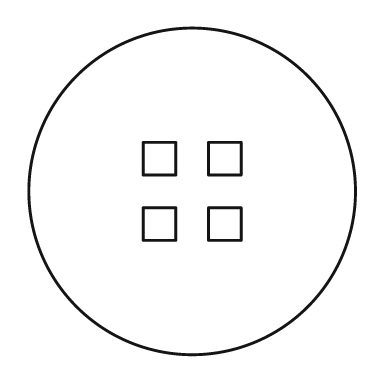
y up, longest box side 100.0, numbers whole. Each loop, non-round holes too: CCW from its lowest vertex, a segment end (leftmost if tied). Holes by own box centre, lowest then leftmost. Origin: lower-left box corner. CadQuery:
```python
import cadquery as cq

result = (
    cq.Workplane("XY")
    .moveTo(50.0, 50.0)
    .circle(50.0)
    .moveTo(35.0, 35.0)
    .lineTo(45.0, 35.0)
    .lineTo(45.0, 45.0)
    .lineTo(35.0, 45.0)
    .close()
    .moveTo(55.0, 35.0)
    .lineTo(65.0, 35.0)
    .lineTo(65.0, 45.0)
    .lineTo(55.0, 45.0)
    .close()
    .moveTo(35.0, 55.0)
    .lineTo(45.0, 55.0)
    .lineTo(45.0, 65.0)
    .lineTo(35.0, 65.0)
    .close()
    .moveTo(55.0, 55.0)
    .lineTo(65.0, 55.0)
    .lineTo(65.0, 65.0)
    .lineTo(55.0, 65.0)
    .close()
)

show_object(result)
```